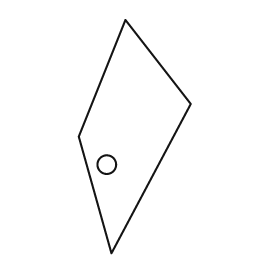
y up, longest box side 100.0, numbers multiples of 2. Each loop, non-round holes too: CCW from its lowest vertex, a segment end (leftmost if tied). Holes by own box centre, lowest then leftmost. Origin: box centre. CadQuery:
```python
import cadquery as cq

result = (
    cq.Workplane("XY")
    .moveTo(-10.0, -50.0)
    .lineTo(24.0, 14.0)
    .lineTo(-4.0, 50.0)
    .lineTo(-24.0, 0.0)
    .close()
    .moveTo(-12.0, -12.0)
    .circle(4.0)
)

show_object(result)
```